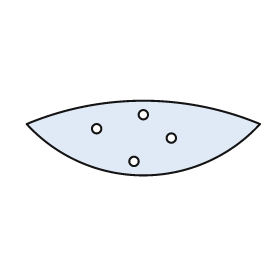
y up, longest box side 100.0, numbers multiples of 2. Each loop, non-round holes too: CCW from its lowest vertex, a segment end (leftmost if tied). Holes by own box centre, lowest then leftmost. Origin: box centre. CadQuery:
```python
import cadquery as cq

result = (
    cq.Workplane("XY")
    .moveTo(-50.0, 6.0)
    .threePointArc((0.0, -16.0), (50.0, 6.0))
    .threePointArc((0.0, 16.0), (-50.0, 6.0))
    .close()
    .moveTo(-4.0, -10.0)
    .circle(2.0)
    .moveTo(12.0, 0.0)
    .circle(2.0)
    .moveTo(-20.0, 4.0)
    .circle(2.0)
    .moveTo(0.0, 10.0)
    .circle(2.0)
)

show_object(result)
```